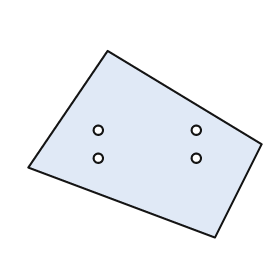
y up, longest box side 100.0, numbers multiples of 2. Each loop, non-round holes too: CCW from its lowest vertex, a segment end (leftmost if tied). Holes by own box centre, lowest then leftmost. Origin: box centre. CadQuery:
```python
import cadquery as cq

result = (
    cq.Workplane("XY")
    .moveTo(30.0, -40.0)
    .lineTo(50.0, 0.0)
    .lineTo(-16.0, 40.0)
    .lineTo(-50.0, -10.0)
    .close()
    .moveTo(-20.0, -6.0)
    .circle(2.0)
    .moveTo(22.0, -6.0)
    .circle(2.0)
    .moveTo(-20.0, 6.0)
    .circle(2.0)
    .moveTo(22.0, 6.0)
    .circle(2.0)
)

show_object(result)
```